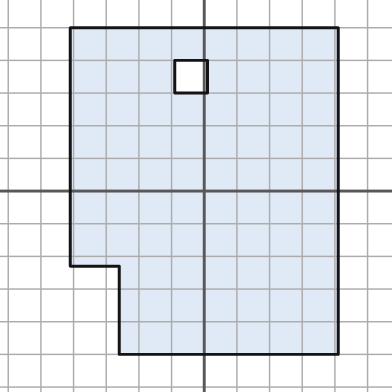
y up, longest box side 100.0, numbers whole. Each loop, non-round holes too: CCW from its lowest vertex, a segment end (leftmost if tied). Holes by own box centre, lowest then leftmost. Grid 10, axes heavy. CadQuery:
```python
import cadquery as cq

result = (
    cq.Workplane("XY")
    .moveTo(-26.0, -50.0)
    .lineTo(41.0, -50.0)
    .lineTo(41.0, 50.0)
    .lineTo(-41.0, 50.0)
    .lineTo(-41.0, -23.0)
    .lineTo(-26.0, -23.0)
    .close()
    .moveTo(-9.0, 30.0)
    .lineTo(1.0, 30.0)
    .lineTo(1.0, 40.0)
    .lineTo(-9.0, 40.0)
    .close()
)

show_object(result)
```